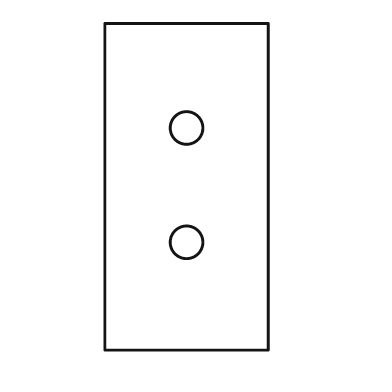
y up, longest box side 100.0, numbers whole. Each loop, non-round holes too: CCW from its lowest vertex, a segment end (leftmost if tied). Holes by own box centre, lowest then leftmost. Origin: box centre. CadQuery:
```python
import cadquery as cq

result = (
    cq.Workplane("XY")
    .moveTo(-25.0, -50.0)
    .lineTo(25.0, -50.0)
    .lineTo(25.0, 50.0)
    .lineTo(-25.0, 50.0)
    .close()
    .moveTo(0.0, -17.0)
    .circle(5.0)
    .moveTo(0.0, 18.0)
    .circle(5.0)
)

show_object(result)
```